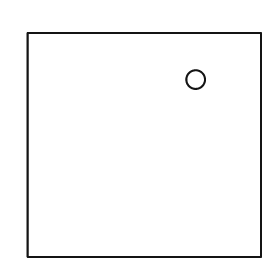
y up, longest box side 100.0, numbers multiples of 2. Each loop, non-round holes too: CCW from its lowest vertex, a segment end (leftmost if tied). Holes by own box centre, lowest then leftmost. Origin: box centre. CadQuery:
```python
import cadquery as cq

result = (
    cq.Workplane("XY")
    .moveTo(-50.0, -48.0)
    .lineTo(50.0, -48.0)
    .lineTo(50.0, 48.0)
    .lineTo(-50.0, 48.0)
    .close()
    .moveTo(22.0, 28.0)
    .circle(4.0)
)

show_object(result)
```